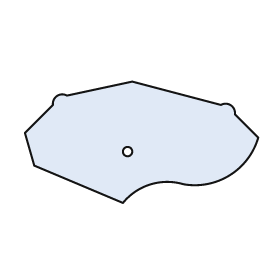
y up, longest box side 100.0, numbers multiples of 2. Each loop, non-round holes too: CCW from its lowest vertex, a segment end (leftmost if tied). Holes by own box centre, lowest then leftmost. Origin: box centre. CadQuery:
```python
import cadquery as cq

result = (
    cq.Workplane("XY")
    .moveTo(-8.0, -26.0)
    .threePointArc((4.0, -18.0), (18.0, -18.0))
    .threePointArc((38.0, -14.0), (50.0, 2.0))
    .lineTo(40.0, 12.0)
    .threePointArc((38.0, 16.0), (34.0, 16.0))
    .lineTo(-4.0, 26.0)
    .lineTo(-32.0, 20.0)
    .threePointArc((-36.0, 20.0), (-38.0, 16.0))
    .lineTo(-50.0, 4.0)
    .lineTo(-46.0, -10.0)
    .close()
    .moveTo(-6.0, -4.0)
    .circle(2.0)
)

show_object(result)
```